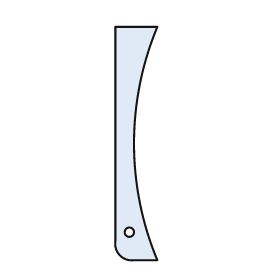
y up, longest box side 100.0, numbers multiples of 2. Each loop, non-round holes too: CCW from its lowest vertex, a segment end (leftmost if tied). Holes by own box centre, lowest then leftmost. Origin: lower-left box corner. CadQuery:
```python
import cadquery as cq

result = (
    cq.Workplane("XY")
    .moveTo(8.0, 0.0)
    .lineTo(18.0, 0.0)
    .threePointArc((8.0, 50.0), (18.0, 100.0))
    .lineTo(0.0, 100.0)
    .lineTo(0.0, 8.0)
    .threePointArc((2.0, 2.0), (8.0, 0.0))
    .close()
    .moveTo(6.0, 12.0)
    .circle(2.0)
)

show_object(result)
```